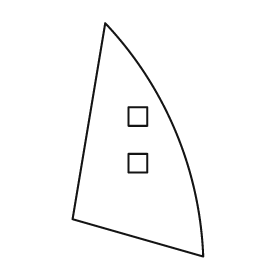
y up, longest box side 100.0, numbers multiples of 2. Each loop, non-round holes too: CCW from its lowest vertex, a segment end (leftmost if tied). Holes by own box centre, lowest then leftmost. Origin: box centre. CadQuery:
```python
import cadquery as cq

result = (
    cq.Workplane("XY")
    .moveTo(28.0, -50.0)
    .threePointArc((16.0, 4.0), (-14.0, 50.0))
    .lineTo(-28.0, -34.0)
    .close()
    .moveTo(-4.0, -14.0)
    .lineTo(4.0, -14.0)
    .lineTo(4.0, -6.0)
    .lineTo(-4.0, -6.0)
    .close()
    .moveTo(-4.0, 6.0)
    .lineTo(4.0, 6.0)
    .lineTo(4.0, 14.0)
    .lineTo(-4.0, 14.0)
    .close()
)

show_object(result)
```